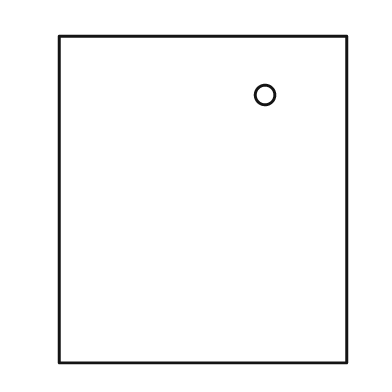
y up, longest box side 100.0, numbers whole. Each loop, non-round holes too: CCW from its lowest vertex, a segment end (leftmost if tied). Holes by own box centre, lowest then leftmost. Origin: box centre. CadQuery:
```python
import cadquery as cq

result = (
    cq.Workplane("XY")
    .moveTo(-44.0, -50.0)
    .lineTo(44.0, -50.0)
    .lineTo(44.0, 50.0)
    .lineTo(-44.0, 50.0)
    .close()
    .moveTo(19.0, 32.0)
    .circle(3.0)
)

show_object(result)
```